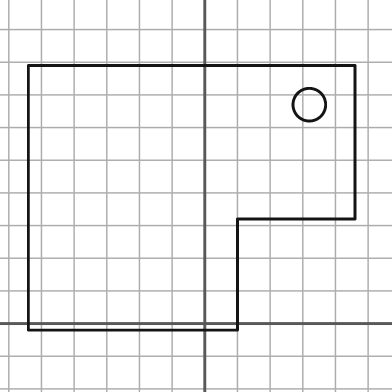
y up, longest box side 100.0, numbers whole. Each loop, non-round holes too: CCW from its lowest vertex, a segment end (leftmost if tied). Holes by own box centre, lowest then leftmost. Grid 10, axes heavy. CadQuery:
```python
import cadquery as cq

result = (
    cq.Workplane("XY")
    .moveTo(-54.0, -2.0)
    .lineTo(10.0, -2.0)
    .lineTo(10.0, 32.0)
    .lineTo(46.0, 32.0)
    .lineTo(46.0, 79.0)
    .lineTo(-54.0, 79.0)
    .close()
    .moveTo(32.0, 67.0)
    .circle(5.0)
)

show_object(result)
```